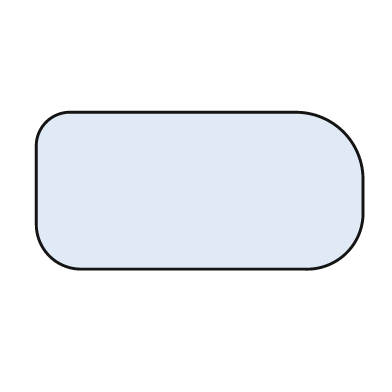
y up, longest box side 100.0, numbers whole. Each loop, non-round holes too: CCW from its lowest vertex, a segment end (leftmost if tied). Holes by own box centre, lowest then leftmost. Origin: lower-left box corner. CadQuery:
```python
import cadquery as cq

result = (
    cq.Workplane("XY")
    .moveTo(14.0, 0.0)
    .lineTo(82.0, 0.0)
    .threePointArc((95.0, 5.0), (100.0, 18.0))
    .lineTo(100.0, 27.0)
    .threePointArc((94.0, 42.0), (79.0, 48.0))
    .lineTo(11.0, 48.0)
    .threePointArc((3.0, 45.0), (0.0, 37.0))
    .lineTo(0.0, 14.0)
    .threePointArc((4.0, 4.0), (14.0, 0.0))
    .close()
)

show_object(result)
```